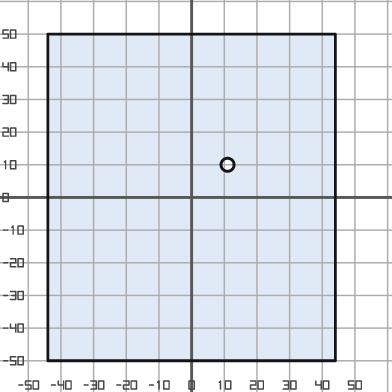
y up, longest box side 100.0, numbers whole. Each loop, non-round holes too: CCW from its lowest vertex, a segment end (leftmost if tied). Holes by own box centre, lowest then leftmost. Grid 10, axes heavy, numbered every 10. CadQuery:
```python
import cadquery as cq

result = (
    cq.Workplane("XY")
    .moveTo(-44.0, -50.0)
    .lineTo(44.0, -50.0)
    .lineTo(44.0, 50.0)
    .lineTo(-44.0, 50.0)
    .close()
    .moveTo(11.0, 10.0)
    .circle(2.0)
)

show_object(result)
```